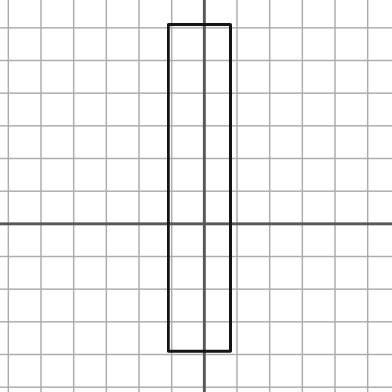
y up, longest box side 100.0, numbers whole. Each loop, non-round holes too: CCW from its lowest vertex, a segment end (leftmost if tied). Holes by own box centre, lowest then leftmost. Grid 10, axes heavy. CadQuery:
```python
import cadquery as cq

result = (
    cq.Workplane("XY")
    .moveTo(-11.0, -39.0)
    .lineTo(8.0, -39.0)
    .lineTo(8.0, 61.0)
    .lineTo(-11.0, 61.0)
    .close()
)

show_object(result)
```